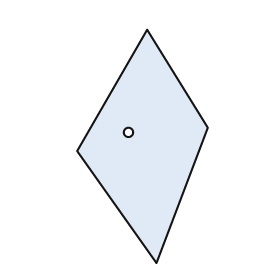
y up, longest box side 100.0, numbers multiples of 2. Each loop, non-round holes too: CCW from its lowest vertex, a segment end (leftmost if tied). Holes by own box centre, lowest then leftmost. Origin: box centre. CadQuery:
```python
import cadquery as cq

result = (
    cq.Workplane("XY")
    .moveTo(6.0, -50.0)
    .lineTo(28.0, 8.0)
    .lineTo(2.0, 50.0)
    .lineTo(-28.0, -2.0)
    .close()
    .moveTo(-6.0, 6.0)
    .circle(2.0)
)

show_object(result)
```